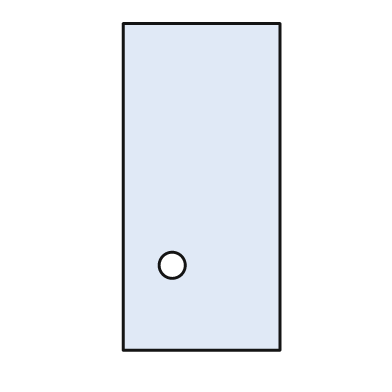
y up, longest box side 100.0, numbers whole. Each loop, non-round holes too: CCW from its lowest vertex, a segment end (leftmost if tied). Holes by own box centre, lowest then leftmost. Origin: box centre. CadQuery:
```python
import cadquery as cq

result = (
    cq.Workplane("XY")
    .moveTo(-24.0, -50.0)
    .lineTo(24.0, -50.0)
    .lineTo(24.0, 50.0)
    .lineTo(-24.0, 50.0)
    .close()
    .moveTo(-9.0, -24.0)
    .circle(4.0)
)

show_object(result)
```